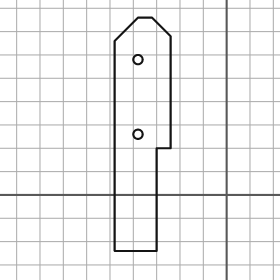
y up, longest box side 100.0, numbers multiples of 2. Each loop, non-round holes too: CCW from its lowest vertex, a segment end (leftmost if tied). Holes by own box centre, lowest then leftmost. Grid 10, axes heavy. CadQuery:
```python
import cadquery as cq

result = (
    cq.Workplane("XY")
    .moveTo(-48.0, -24.0)
    .lineTo(-30.0, -24.0)
    .lineTo(-30.0, 20.0)
    .lineTo(-24.0, 20.0)
    .lineTo(-24.0, 68.0)
    .lineTo(-32.0, 76.0)
    .lineTo(-38.0, 76.0)
    .lineTo(-48.0, 66.0)
    .close()
    .moveTo(-38.0, 26.0)
    .circle(2.0)
    .moveTo(-38.0, 58.0)
    .circle(2.0)
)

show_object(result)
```